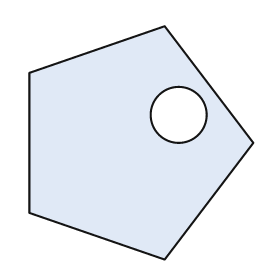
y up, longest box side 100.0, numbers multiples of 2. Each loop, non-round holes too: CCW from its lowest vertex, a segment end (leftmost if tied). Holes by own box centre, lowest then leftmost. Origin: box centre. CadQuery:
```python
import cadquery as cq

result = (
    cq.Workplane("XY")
    .moveTo(10.0, -50.0)
    .lineTo(48.0, 0.0)
    .lineTo(10.0, 50.0)
    .lineTo(-48.0, 30.0)
    .lineTo(-48.0, -30.0)
    .close()
    .moveTo(16.0, 12.0)
    .circle(12.0)
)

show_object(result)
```